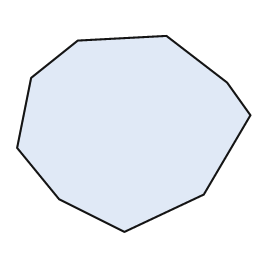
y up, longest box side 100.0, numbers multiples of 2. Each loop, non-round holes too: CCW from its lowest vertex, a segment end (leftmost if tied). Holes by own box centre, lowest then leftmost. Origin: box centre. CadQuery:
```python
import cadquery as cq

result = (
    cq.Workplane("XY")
    .moveTo(-4.0, -42.0)
    .lineTo(30.0, -26.0)
    .lineTo(50.0, 8.0)
    .lineTo(40.0, 22.0)
    .lineTo(14.0, 42.0)
    .lineTo(-24.0, 40.0)
    .lineTo(-44.0, 24.0)
    .lineTo(-50.0, -6.0)
    .lineTo(-32.0, -28.0)
    .close()
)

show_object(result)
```